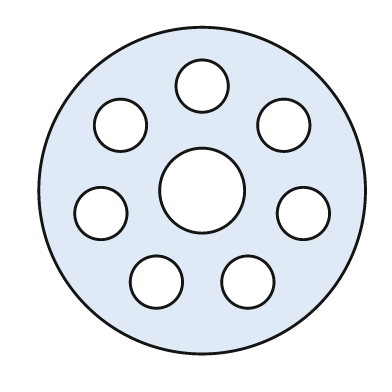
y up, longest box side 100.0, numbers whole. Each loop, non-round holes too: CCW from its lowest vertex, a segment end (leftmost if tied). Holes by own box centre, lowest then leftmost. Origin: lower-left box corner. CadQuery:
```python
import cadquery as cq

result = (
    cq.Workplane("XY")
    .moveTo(50.0, 50.0)
    .circle(50.0)
    .moveTo(36.0, 22.0)
    .circle(8.0)
    .moveTo(64.0, 22.0)
    .circle(8.0)
    .moveTo(19.0, 43.0)
    .circle(8.0)
    .moveTo(81.0, 43.0)
    .circle(8.0)
    .moveTo(50.0, 50.0)
    .circle(13.0)
    .moveTo(25.0, 70.0)
    .circle(8.0)
    .moveTo(75.0, 70.0)
    .circle(8.0)
    .moveTo(50.0, 82.0)
    .circle(8.0)
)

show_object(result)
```